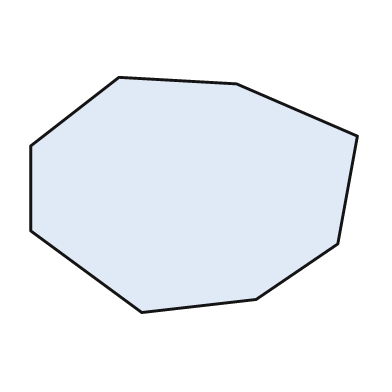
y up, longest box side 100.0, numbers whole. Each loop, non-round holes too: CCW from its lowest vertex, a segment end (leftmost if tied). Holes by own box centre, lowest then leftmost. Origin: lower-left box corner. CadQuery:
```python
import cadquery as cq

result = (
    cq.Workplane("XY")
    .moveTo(34.0, 0.0)
    .lineTo(69.0, 4.0)
    .lineTo(94.0, 21.0)
    .lineTo(100.0, 54.0)
    .lineTo(63.0, 70.0)
    .lineTo(27.0, 72.0)
    .lineTo(0.0, 51.0)
    .lineTo(0.0, 25.0)
    .close()
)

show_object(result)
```